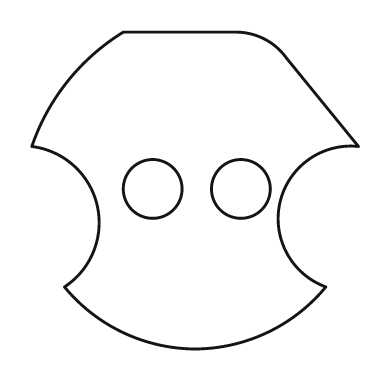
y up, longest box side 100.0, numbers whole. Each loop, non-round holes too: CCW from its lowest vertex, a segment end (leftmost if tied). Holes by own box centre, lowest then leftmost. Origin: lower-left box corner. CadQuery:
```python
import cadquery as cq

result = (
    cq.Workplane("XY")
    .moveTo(50.0, 0.0)
    .threePointArc((72.0, 5.0), (90.0, 19.0))
    .threePointArc((76.0, 45.0), (100.0, 62.0))
    .lineTo(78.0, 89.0)
    .threePointArc((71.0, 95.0), (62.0, 97.0))
    .lineTo(28.0, 97.0)
    .threePointArc((11.0, 82.0), (0.0, 62.0))
    .threePointArc((20.0, 44.0), (10.0, 19.0))
    .threePointArc((28.0, 5.0), (50.0, 0.0))
    .close()
    .moveTo(37.0, 49.0)
    .circle(9.0)
    .moveTo(64.0, 49.0)
    .circle(9.0)
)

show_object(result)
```